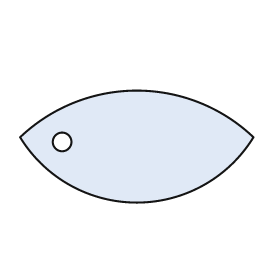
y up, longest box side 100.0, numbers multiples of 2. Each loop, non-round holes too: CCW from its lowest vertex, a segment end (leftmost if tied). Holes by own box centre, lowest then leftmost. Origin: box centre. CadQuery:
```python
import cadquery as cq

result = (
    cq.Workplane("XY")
    .moveTo(-50.0, 4.0)
    .threePointArc((0.0, -24.0), (50.0, 4.0))
    .threePointArc((0.0, 24.0), (-50.0, 4.0))
    .close()
    .moveTo(-32.0, 2.0)
    .circle(4.0)
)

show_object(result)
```